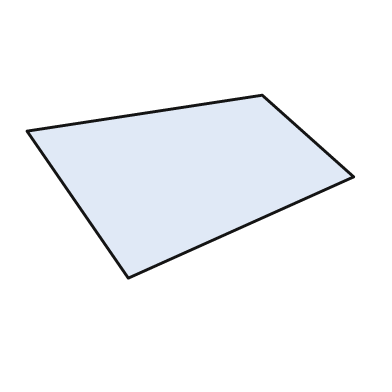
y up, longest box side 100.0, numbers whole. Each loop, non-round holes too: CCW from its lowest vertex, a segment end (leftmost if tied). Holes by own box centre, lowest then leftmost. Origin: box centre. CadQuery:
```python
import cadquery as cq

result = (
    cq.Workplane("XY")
    .moveTo(-19.0, -28.0)
    .lineTo(50.0, 3.0)
    .lineTo(22.0, 28.0)
    .lineTo(-50.0, 17.0)
    .close()
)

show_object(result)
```